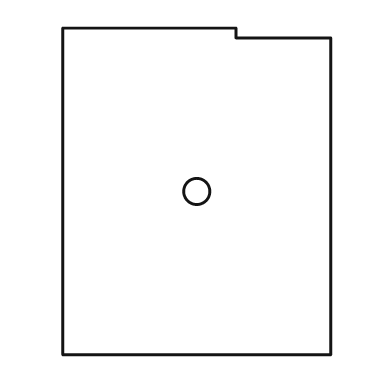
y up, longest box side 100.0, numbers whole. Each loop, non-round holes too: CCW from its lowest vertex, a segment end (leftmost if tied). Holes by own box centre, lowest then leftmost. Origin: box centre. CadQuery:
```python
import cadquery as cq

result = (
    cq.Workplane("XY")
    .moveTo(-41.0, -50.0)
    .lineTo(41.0, -50.0)
    .lineTo(41.0, 47.0)
    .lineTo(12.0, 47.0)
    .lineTo(12.0, 50.0)
    .lineTo(-41.0, 50.0)
    .close()
    .moveTo(0.0, 0.0)
    .circle(4.0)
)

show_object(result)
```